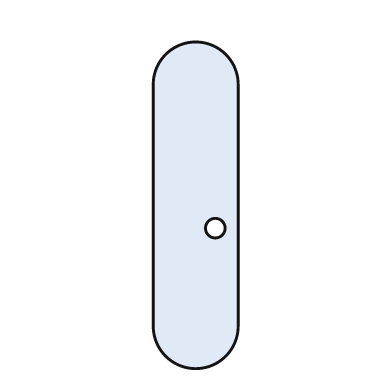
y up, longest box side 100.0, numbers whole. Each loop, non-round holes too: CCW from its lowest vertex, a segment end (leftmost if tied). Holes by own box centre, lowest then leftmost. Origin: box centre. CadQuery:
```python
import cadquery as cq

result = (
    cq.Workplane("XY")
    .moveTo(-13.0, -37.0)
    .threePointArc((0.0, -50.0), (13.0, -37.0))
    .lineTo(13.0, 37.0)
    .threePointArc((0.0, 50.0), (-13.0, 37.0))
    .close()
    .moveTo(6.0, -7.0)
    .circle(3.0)
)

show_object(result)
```